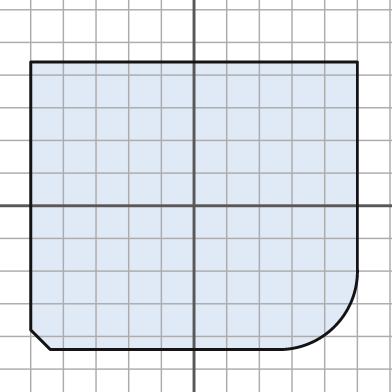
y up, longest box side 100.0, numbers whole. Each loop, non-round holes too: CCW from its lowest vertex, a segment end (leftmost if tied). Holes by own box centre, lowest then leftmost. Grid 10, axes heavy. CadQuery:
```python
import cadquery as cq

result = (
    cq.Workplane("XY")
    .moveTo(-44.0, -44.0)
    .lineTo(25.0, -44.0)
    .threePointArc((43.0, -37.0), (50.0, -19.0))
    .lineTo(50.0, 44.0)
    .lineTo(-50.0, 44.0)
    .lineTo(-50.0, -38.0)
    .close()
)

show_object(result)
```